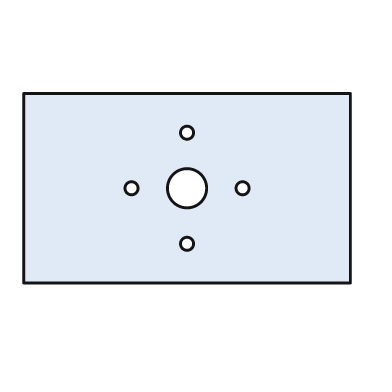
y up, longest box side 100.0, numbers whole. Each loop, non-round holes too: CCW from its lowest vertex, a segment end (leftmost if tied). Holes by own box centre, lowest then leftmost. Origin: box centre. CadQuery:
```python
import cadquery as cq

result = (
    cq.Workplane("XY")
    .moveTo(-50.0, -29.0)
    .lineTo(50.0, -29.0)
    .lineTo(50.0, 29.0)
    .lineTo(-50.0, 29.0)
    .close()
    .moveTo(0.0, -17.0)
    .circle(2.0)
    .moveTo(-17.0, 0.0)
    .circle(2.0)
    .moveTo(0.0, 0.0)
    .circle(6.0)
    .moveTo(17.0, 0.0)
    .circle(2.0)
    .moveTo(0.0, 17.0)
    .circle(2.0)
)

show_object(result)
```